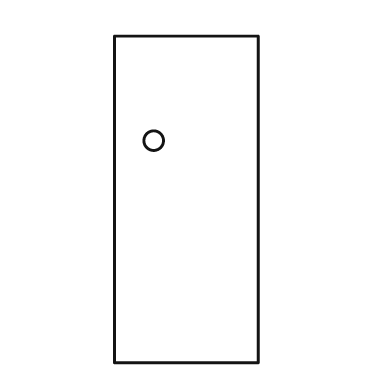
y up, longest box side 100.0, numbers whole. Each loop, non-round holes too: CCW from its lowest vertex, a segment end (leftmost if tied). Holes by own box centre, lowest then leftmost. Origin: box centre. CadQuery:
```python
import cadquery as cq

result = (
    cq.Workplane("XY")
    .moveTo(-22.0, -50.0)
    .lineTo(22.0, -50.0)
    .lineTo(22.0, 50.0)
    .lineTo(-22.0, 50.0)
    .close()
    .moveTo(-10.0, 18.0)
    .circle(3.0)
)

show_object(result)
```